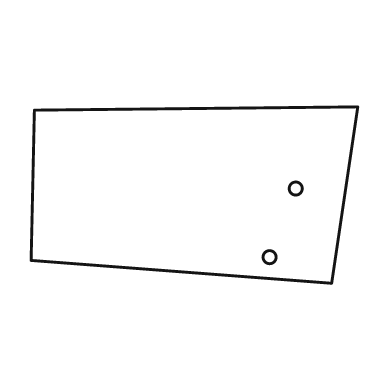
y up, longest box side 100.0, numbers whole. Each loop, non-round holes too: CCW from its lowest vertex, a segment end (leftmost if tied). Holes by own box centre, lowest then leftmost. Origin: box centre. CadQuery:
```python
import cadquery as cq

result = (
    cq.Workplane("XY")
    .moveTo(42.0, -27.0)
    .lineTo(50.0, 27.0)
    .lineTo(-49.0, 26.0)
    .lineTo(-50.0, -20.0)
    .close()
    .moveTo(23.0, -19.0)
    .circle(2.0)
    .moveTo(31.0, 2.0)
    .circle(2.0)
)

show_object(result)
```